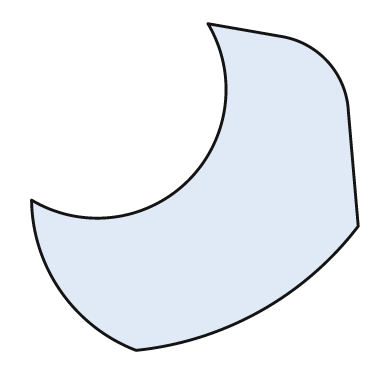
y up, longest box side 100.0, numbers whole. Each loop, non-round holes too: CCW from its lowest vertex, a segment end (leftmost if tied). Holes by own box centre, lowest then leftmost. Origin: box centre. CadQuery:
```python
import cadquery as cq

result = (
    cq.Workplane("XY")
    .moveTo(-18.0, -50.0)
    .threePointArc((20.0, -38.0), (50.0, -12.0))
    .lineTo(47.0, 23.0)
    .threePointArc((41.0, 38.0), (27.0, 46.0))
    .lineTo(4.0, 50.0)
    .threePointArc((-2.0, 2.0), (-50.0, -4.0))
    .threePointArc((-41.0, -32.0), (-18.0, -50.0))
    .close()
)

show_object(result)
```